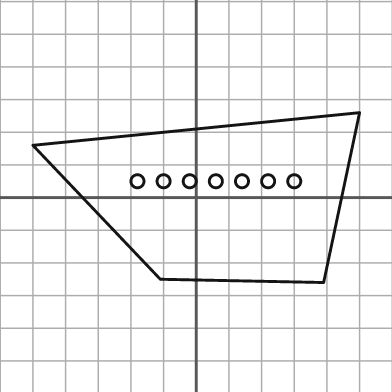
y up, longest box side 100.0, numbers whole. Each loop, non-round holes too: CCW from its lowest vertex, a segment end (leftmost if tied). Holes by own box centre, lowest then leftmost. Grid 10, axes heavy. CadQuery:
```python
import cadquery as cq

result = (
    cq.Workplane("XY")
    .moveTo(39.0, -26.0)
    .lineTo(50.0, 26.0)
    .lineTo(-50.0, 16.0)
    .lineTo(-11.0, -25.0)
    .close()
    .moveTo(-18.0, 5.0)
    .circle(2.0)
    .moveTo(-10.0, 5.0)
    .circle(2.0)
    .moveTo(-2.0, 5.0)
    .circle(2.0)
    .moveTo(6.0, 5.0)
    .circle(2.0)
    .moveTo(14.0, 5.0)
    .circle(2.0)
    .moveTo(22.0, 5.0)
    .circle(2.0)
    .moveTo(30.0, 5.0)
    .circle(2.0)
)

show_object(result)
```